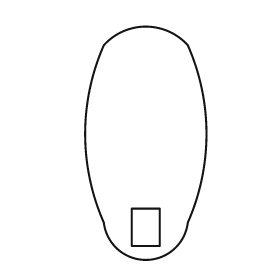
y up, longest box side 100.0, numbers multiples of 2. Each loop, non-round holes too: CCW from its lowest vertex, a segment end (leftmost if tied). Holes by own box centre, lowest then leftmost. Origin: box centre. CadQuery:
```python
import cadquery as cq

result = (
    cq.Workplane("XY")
    .moveTo(-18.0, -34.0)
    .threePointArc((0.0, -50.0), (18.0, -34.0))
    .threePointArc((26.0, 4.0), (18.0, 42.0))
    .threePointArc((0.0, 50.0), (-18.0, 42.0))
    .threePointArc((-26.0, 4.0), (-18.0, -34.0))
    .close()
    .moveTo(-6.0, -44.0)
    .lineTo(6.0, -44.0)
    .lineTo(6.0, -28.0)
    .lineTo(-6.0, -28.0)
    .close()
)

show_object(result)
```